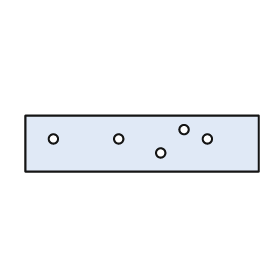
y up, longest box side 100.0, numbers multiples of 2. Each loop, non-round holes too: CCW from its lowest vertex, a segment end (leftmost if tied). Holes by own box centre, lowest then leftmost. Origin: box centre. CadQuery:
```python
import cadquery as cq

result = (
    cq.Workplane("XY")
    .moveTo(-50.0, -12.0)
    .lineTo(50.0, -12.0)
    .lineTo(50.0, 12.0)
    .lineTo(-50.0, 12.0)
    .close()
    .moveTo(8.0, -4.0)
    .circle(2.0)
    .moveTo(-38.0, 2.0)
    .circle(2.0)
    .moveTo(-10.0, 2.0)
    .circle(2.0)
    .moveTo(28.0, 2.0)
    .circle(2.0)
    .moveTo(18.0, 6.0)
    .circle(2.0)
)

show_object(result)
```